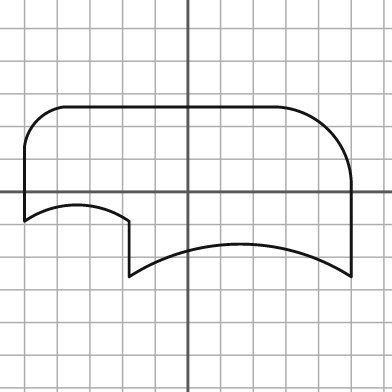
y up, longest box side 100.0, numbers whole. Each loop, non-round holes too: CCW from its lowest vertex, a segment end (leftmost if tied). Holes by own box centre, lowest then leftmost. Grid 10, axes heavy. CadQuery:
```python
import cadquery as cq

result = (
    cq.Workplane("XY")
    .moveTo(-18.0, -26.0)
    .threePointArc((16.0, -16.0), (50.0, -26.0))
    .lineTo(50.0, 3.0)
    .threePointArc((43.0, 19.0), (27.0, 26.0))
    .lineTo(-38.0, 26.0)
    .threePointArc((-46.0, 22.0), (-50.0, 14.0))
    .lineTo(-50.0, -9.0)
    .threePointArc((-34.0, -4.0), (-18.0, -9.0))
    .close()
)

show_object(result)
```